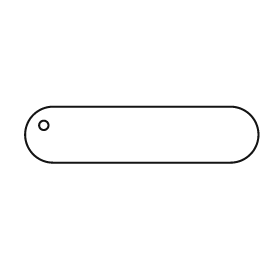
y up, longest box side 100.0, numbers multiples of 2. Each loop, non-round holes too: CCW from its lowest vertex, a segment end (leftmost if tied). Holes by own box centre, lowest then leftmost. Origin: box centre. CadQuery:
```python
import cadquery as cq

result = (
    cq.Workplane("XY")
    .moveTo(-38.0, -12.0)
    .lineTo(38.0, -12.0)
    .threePointArc((50.0, 0.0), (38.0, 12.0))
    .lineTo(-38.0, 12.0)
    .threePointArc((-50.0, 0.0), (-38.0, -12.0))
    .close()
    .moveTo(-42.0, 4.0)
    .circle(2.0)
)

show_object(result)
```